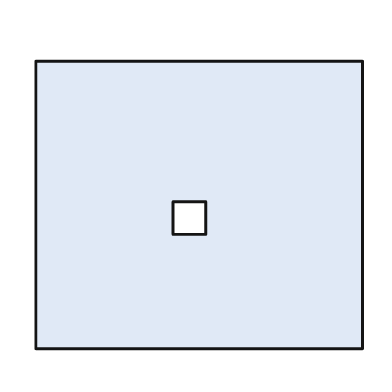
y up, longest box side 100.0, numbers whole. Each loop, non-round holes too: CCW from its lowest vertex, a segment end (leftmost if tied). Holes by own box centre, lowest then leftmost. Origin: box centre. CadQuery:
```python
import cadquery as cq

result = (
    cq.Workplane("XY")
    .moveTo(-50.0, -44.0)
    .lineTo(50.0, -44.0)
    .lineTo(50.0, 44.0)
    .lineTo(-50.0, 44.0)
    .close()
    .moveTo(-8.0, -9.0)
    .lineTo(2.0, -9.0)
    .lineTo(2.0, 1.0)
    .lineTo(-8.0, 1.0)
    .close()
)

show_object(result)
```